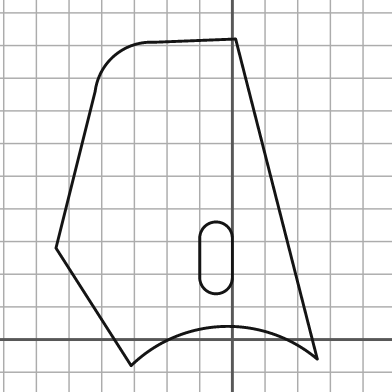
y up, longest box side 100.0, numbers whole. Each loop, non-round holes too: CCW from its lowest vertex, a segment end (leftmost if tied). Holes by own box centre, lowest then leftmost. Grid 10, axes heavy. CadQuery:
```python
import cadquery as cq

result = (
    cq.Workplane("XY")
    .moveTo(-31.0, -8.0)
    .threePointArc((-3.0, 4.0), (26.0, -6.0))
    .lineTo(1.0, 92.0)
    .lineTo(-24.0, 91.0)
    .threePointArc((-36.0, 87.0), (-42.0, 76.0))
    .lineTo(-54.0, 28.0)
    .close()
    .moveTo(-10.0, 19.0)
    .threePointArc((-5.0, 14.0), (0.0, 19.0))
    .lineTo(0.0, 31.0)
    .threePointArc((-5.0, 36.0), (-10.0, 31.0))
    .close()
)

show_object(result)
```